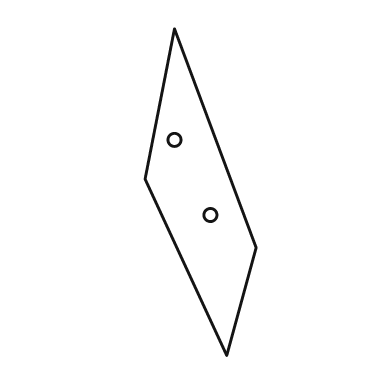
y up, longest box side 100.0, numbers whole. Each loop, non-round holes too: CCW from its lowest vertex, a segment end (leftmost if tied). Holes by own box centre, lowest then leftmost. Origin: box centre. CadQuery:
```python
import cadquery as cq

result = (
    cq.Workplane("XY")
    .moveTo(8.0, -50.0)
    .lineTo(17.0, -17.0)
    .lineTo(-8.0, 50.0)
    .lineTo(-17.0, 4.0)
    .close()
    .moveTo(3.0, -7.0)
    .circle(2.0)
    .moveTo(-8.0, 16.0)
    .circle(2.0)
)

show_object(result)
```